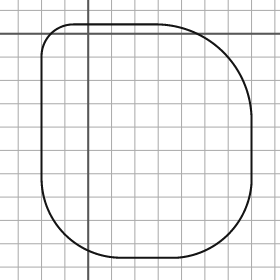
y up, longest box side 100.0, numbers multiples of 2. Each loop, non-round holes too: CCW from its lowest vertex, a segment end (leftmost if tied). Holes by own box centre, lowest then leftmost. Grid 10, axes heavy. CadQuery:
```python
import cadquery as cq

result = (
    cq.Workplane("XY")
    .moveTo(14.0, -96.0)
    .lineTo(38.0, -96.0)
    .threePointArc((60.0, -86.0), (70.0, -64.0))
    .lineTo(70.0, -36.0)
    .threePointArc((58.0, -8.0), (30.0, 4.0))
    .lineTo(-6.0, 4.0)
    .threePointArc((-16.0, 0.0), (-20.0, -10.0))
    .lineTo(-20.0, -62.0)
    .threePointArc((-10.0, -86.0), (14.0, -96.0))
    .close()
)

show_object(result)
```